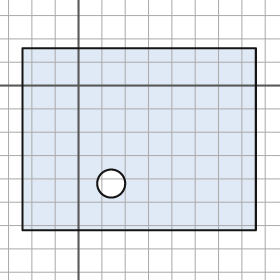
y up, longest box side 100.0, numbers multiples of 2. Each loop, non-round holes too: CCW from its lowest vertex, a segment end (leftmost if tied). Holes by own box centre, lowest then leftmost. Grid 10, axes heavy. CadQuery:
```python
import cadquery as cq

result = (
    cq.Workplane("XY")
    .moveTo(-24.0, -62.0)
    .lineTo(76.0, -62.0)
    .lineTo(76.0, 16.0)
    .lineTo(-24.0, 16.0)
    .close()
    .moveTo(14.0, -42.0)
    .circle(6.0)
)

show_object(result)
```